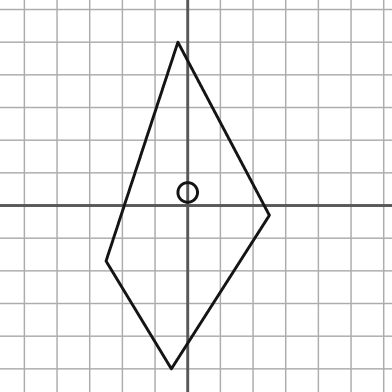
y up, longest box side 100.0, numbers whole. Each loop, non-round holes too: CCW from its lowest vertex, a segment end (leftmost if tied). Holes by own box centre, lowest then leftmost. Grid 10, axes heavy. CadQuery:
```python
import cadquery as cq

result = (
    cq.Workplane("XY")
    .moveTo(-5.0, -50.0)
    .lineTo(25.0, -3.0)
    .lineTo(-3.0, 50.0)
    .lineTo(-25.0, -17.0)
    .close()
    .moveTo(0.0, 4.0)
    .circle(3.0)
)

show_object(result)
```